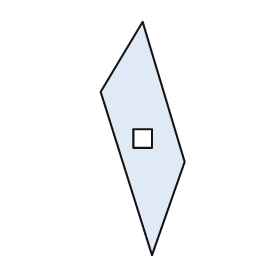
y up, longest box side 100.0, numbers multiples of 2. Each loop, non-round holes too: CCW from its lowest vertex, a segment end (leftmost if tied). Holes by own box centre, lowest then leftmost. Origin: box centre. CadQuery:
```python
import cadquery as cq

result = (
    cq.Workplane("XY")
    .moveTo(4.0, -50.0)
    .lineTo(18.0, -10.0)
    .lineTo(0.0, 50.0)
    .lineTo(-18.0, 20.0)
    .close()
    .moveTo(-4.0, -4.0)
    .lineTo(4.0, -4.0)
    .lineTo(4.0, 4.0)
    .lineTo(-4.0, 4.0)
    .close()
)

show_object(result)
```